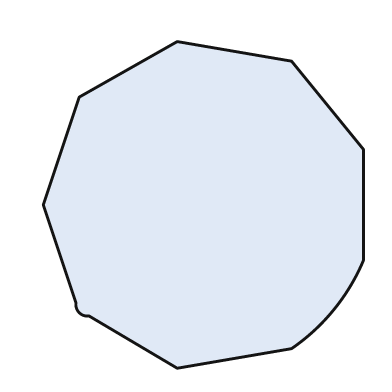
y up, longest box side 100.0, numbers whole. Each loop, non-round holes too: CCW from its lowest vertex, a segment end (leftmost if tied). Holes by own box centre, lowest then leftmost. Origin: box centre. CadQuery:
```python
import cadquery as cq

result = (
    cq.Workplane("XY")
    .moveTo(-8.0, -50.0)
    .lineTo(27.0, -44.0)
    .threePointArc((40.0, -32.0), (49.0, -17.0))
    .lineTo(49.0, 17.0)
    .lineTo(27.0, 44.0)
    .lineTo(-8.0, 50.0)
    .lineTo(-38.0, 33.0)
    .lineTo(-49.0, 0.0)
    .lineTo(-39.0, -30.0)
    .threePointArc((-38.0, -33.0), (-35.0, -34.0))
    .close()
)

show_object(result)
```